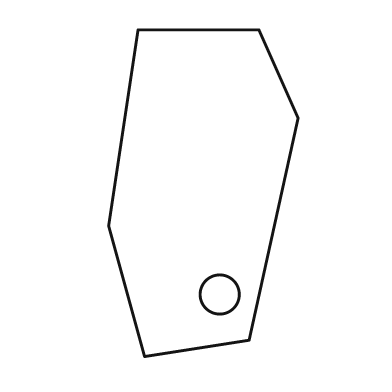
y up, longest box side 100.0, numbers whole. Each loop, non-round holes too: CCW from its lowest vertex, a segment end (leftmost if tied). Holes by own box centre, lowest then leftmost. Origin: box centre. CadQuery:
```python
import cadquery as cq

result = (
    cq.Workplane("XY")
    .moveTo(-18.0, -50.0)
    .lineTo(14.0, -45.0)
    .lineTo(29.0, 23.0)
    .lineTo(17.0, 50.0)
    .lineTo(-20.0, 50.0)
    .lineTo(-29.0, -10.0)
    .close()
    .moveTo(5.0, -31.0)
    .circle(6.0)
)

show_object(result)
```